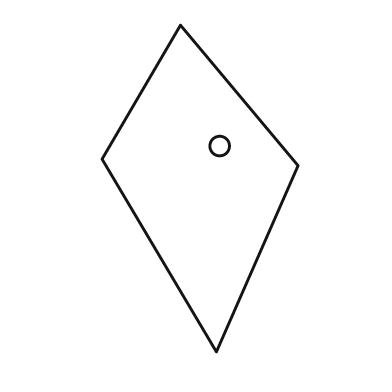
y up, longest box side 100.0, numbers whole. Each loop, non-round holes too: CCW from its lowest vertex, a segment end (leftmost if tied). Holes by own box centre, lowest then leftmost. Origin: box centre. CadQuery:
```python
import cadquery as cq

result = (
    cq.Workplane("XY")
    .moveTo(5.0, -50.0)
    .lineTo(30.0, 7.0)
    .lineTo(-6.0, 50.0)
    .lineTo(-30.0, 9.0)
    .close()
    .moveTo(6.0, 13.0)
    .circle(3.0)
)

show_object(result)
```